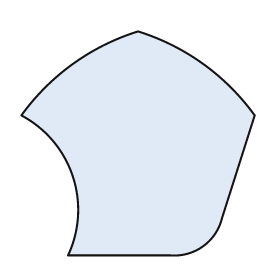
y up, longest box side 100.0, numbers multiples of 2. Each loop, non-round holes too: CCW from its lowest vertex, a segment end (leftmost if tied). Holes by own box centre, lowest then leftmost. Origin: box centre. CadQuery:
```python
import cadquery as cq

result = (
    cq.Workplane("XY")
    .moveTo(-30.0, -48.0)
    .lineTo(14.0, -48.0)
    .threePointArc((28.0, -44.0), (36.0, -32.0))
    .lineTo(50.0, 12.0)
    .threePointArc((28.0, 34.0), (0.0, 48.0))
    .threePointArc((-28.0, 34.0), (-50.0, 12.0))
    .threePointArc((-28.0, -14.0), (-30.0, -48.0))
    .close()
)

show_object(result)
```